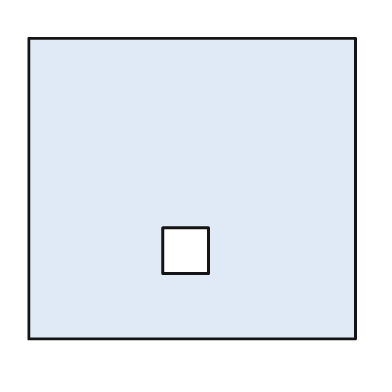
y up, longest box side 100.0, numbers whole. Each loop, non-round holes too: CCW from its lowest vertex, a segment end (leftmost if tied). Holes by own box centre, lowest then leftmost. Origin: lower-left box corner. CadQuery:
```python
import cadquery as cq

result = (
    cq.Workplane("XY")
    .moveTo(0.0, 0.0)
    .lineTo(100.0, 0.0)
    .lineTo(100.0, 92.0)
    .lineTo(0.0, 92.0)
    .close()
    .moveTo(41.0, 20.0)
    .lineTo(55.0, 20.0)
    .lineTo(55.0, 34.0)
    .lineTo(41.0, 34.0)
    .close()
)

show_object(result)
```